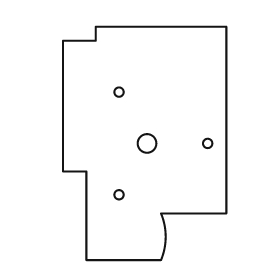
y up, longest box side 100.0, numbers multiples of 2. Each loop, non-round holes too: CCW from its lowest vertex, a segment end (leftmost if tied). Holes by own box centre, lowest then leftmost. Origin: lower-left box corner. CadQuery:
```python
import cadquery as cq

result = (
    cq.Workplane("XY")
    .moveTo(10.0, 0.0)
    .lineTo(42.0, 0.0)
    .threePointArc((44.0, 10.0), (42.0, 20.0))
    .lineTo(70.0, 20.0)
    .lineTo(70.0, 100.0)
    .lineTo(14.0, 100.0)
    .lineTo(14.0, 94.0)
    .lineTo(0.0, 94.0)
    .lineTo(0.0, 38.0)
    .lineTo(10.0, 38.0)
    .close()
    .moveTo(24.0, 28.0)
    .circle(2.0)
    .moveTo(36.0, 50.0)
    .circle(4.0)
    .moveTo(62.0, 50.0)
    .circle(2.0)
    .moveTo(24.0, 72.0)
    .circle(2.0)
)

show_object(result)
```